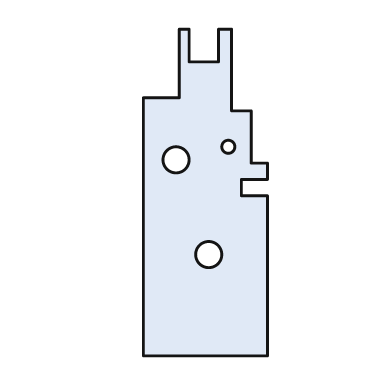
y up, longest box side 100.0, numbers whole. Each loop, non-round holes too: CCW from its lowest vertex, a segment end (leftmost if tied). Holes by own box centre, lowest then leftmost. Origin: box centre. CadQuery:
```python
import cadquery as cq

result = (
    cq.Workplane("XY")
    .moveTo(-19.0, -50.0)
    .lineTo(19.0, -50.0)
    .lineTo(19.0, -1.0)
    .lineTo(11.0, -1.0)
    .lineTo(11.0, 4.0)
    .lineTo(19.0, 4.0)
    .lineTo(19.0, 9.0)
    .lineTo(14.0, 9.0)
    .lineTo(14.0, 25.0)
    .lineTo(8.0, 25.0)
    .lineTo(8.0, 50.0)
    .lineTo(4.0, 50.0)
    .lineTo(4.0, 40.0)
    .lineTo(-5.0, 40.0)
    .lineTo(-5.0, 50.0)
    .lineTo(-8.0, 50.0)
    .lineTo(-8.0, 29.0)
    .lineTo(-19.0, 29.0)
    .close()
    .moveTo(1.0, -19.0)
    .circle(4.0)
    .moveTo(-9.0, 10.0)
    .circle(4.0)
    .moveTo(7.0, 14.0)
    .circle(2.0)
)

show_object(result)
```